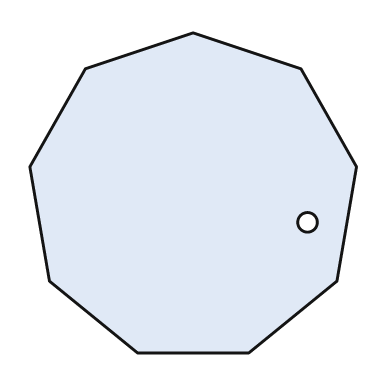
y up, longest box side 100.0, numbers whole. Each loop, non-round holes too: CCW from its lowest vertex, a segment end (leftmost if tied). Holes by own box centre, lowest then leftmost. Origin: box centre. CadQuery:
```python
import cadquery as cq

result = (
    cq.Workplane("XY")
    .moveTo(-17.0, -49.0)
    .lineTo(17.0, -49.0)
    .lineTo(44.0, -27.0)
    .lineTo(50.0, 8.0)
    .lineTo(33.0, 38.0)
    .lineTo(0.0, 49.0)
    .lineTo(-33.0, 38.0)
    .lineTo(-50.0, 8.0)
    .lineTo(-44.0, -27.0)
    .close()
    .moveTo(35.0, -9.0)
    .circle(3.0)
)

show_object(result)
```